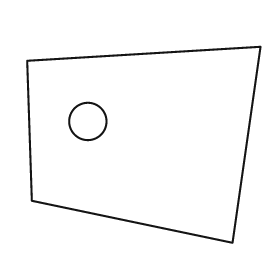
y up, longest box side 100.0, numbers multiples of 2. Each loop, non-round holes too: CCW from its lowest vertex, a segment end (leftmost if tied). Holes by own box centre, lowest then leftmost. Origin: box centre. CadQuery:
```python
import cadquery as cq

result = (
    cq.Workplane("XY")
    .moveTo(38.0, -42.0)
    .lineTo(50.0, 42.0)
    .lineTo(-50.0, 36.0)
    .lineTo(-48.0, -24.0)
    .close()
    .moveTo(-24.0, 10.0)
    .circle(8.0)
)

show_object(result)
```